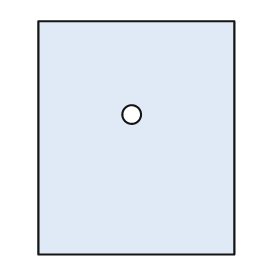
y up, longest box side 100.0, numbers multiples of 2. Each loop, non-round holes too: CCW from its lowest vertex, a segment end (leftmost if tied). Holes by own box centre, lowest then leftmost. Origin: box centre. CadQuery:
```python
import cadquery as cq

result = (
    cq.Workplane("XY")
    .moveTo(-42.0, -50.0)
    .lineTo(42.0, -50.0)
    .lineTo(42.0, 50.0)
    .lineTo(-42.0, 50.0)
    .close()
    .moveTo(-2.0, 10.0)
    .circle(4.0)
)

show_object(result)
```